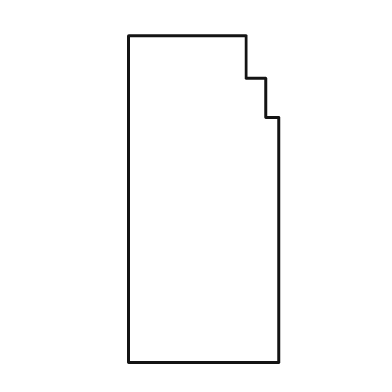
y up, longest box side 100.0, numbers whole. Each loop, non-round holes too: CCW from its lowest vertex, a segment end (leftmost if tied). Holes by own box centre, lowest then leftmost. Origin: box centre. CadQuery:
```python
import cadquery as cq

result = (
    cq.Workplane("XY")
    .moveTo(-23.0, -50.0)
    .lineTo(23.0, -50.0)
    .lineTo(23.0, 25.0)
    .lineTo(19.0, 25.0)
    .lineTo(19.0, 37.0)
    .lineTo(13.0, 37.0)
    .lineTo(13.0, 50.0)
    .lineTo(-23.0, 50.0)
    .close()
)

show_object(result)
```